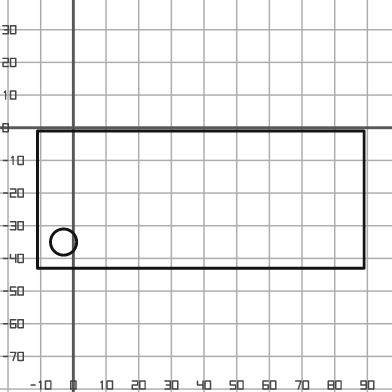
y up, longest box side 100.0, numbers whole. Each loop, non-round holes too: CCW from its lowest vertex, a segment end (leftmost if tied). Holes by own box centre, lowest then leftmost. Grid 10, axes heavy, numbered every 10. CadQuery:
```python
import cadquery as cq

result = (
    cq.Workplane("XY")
    .moveTo(-11.0, -43.0)
    .lineTo(89.0, -43.0)
    .lineTo(89.0, -1.0)
    .lineTo(-11.0, -1.0)
    .close()
    .moveTo(-3.0, -35.0)
    .circle(4.0)
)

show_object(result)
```